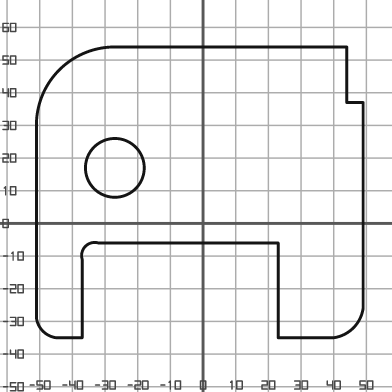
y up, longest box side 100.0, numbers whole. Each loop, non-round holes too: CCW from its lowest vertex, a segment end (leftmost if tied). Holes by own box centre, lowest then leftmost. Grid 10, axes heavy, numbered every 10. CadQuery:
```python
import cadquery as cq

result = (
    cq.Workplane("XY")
    .moveTo(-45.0, -35.0)
    .lineTo(-37.0, -35.0)
    .lineTo(-37.0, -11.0)
    .threePointArc((-36.0, -7.0), (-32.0, -6.0))
    .lineTo(23.0, -6.0)
    .lineTo(23.0, -35.0)
    .lineTo(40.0, -35.0)
    .threePointArc((46.0, -32.0), (49.0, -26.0))
    .lineTo(49.0, 37.0)
    .lineTo(44.0, 37.0)
    .lineTo(44.0, 54.0)
    .lineTo(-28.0, 54.0)
    .threePointArc((-44.0, 47.0), (-51.0, 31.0))
    .lineTo(-51.0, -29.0)
    .threePointArc((-49.0, -33.0), (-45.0, -35.0))
    .close()
    .moveTo(-27.0, 17.0)
    .circle(9.0)
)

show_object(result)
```